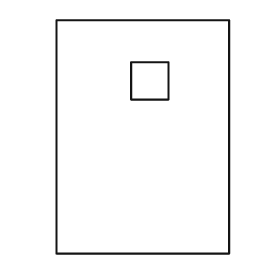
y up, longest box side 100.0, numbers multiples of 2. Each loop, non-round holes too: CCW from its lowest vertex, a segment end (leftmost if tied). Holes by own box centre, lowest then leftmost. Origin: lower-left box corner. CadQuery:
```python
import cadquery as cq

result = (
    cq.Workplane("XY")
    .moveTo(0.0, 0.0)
    .lineTo(74.0, 0.0)
    .lineTo(74.0, 100.0)
    .lineTo(0.0, 100.0)
    .close()
    .moveTo(32.0, 66.0)
    .lineTo(48.0, 66.0)
    .lineTo(48.0, 82.0)
    .lineTo(32.0, 82.0)
    .close()
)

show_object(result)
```